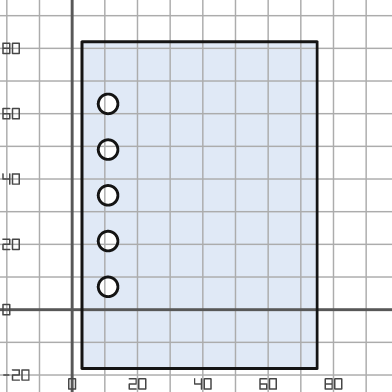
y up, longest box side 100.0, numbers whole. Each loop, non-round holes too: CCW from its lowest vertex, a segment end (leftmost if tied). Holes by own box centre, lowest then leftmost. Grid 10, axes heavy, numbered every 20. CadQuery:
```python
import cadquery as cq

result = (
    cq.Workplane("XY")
    .moveTo(3.0, -18.0)
    .lineTo(75.0, -18.0)
    .lineTo(75.0, 82.0)
    .lineTo(3.0, 82.0)
    .close()
    .moveTo(11.0, 7.0)
    .circle(3.0)
    .moveTo(11.0, 21.0)
    .circle(3.0)
    .moveTo(11.0, 35.0)
    .circle(3.0)
    .moveTo(11.0, 49.0)
    .circle(3.0)
    .moveTo(11.0, 63.0)
    .circle(3.0)
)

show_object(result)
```